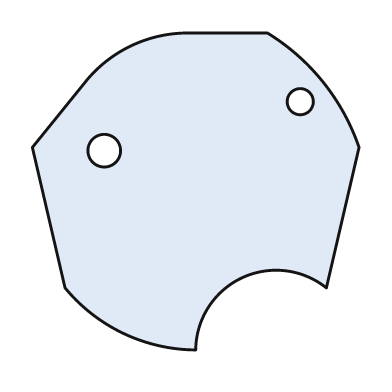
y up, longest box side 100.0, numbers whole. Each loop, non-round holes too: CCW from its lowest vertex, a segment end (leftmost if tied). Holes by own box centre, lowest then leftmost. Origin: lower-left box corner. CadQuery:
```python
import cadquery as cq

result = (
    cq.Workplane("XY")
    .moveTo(50.0, 0.0)
    .threePointArc((64.0, 22.0), (90.0, 19.0))
    .lineTo(100.0, 62.0)
    .threePointArc((89.0, 82.0), (72.0, 97.0))
    .lineTo(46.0, 97.0)
    .threePointArc((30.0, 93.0), (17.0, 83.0))
    .lineTo(0.0, 62.0)
    .lineTo(10.0, 19.0)
    .threePointArc((28.0, 5.0), (50.0, 0.0))
    .close()
    .moveTo(22.0, 61.0)
    .circle(5.0)
    .moveTo(82.0, 76.0)
    .circle(4.0)
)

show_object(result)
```